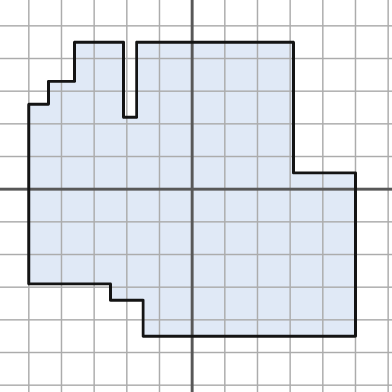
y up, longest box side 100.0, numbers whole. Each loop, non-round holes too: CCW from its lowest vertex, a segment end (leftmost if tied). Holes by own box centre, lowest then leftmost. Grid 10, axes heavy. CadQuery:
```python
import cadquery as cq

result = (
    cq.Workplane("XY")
    .moveTo(-15.0, -45.0)
    .lineTo(50.0, -45.0)
    .lineTo(50.0, 5.0)
    .lineTo(31.0, 5.0)
    .lineTo(31.0, 45.0)
    .lineTo(-17.0, 45.0)
    .lineTo(-17.0, 22.0)
    .lineTo(-21.0, 22.0)
    .lineTo(-21.0, 45.0)
    .lineTo(-36.0, 45.0)
    .lineTo(-36.0, 33.0)
    .lineTo(-44.0, 33.0)
    .lineTo(-44.0, 26.0)
    .lineTo(-50.0, 26.0)
    .lineTo(-50.0, -29.0)
    .lineTo(-25.0, -29.0)
    .lineTo(-25.0, -34.0)
    .lineTo(-15.0, -34.0)
    .close()
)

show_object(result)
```